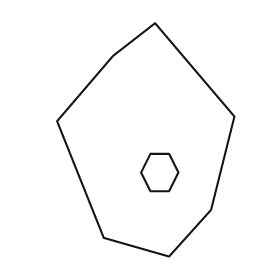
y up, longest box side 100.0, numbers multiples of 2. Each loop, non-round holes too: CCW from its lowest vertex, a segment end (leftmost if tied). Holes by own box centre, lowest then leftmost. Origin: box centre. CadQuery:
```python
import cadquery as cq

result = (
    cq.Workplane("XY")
    .moveTo(10.0, -50.0)
    .lineTo(28.0, -30.0)
    .lineTo(38.0, 10.0)
    .lineTo(4.0, 50.0)
    .lineTo(-14.0, 36.0)
    .lineTo(-38.0, 8.0)
    .lineTo(-18.0, -42.0)
    .close()
    .moveTo(2.0, -22.0)
    .lineTo(10.0, -22.0)
    .lineTo(14.0, -14.0)
    .lineTo(10.0, -6.0)
    .lineTo(2.0, -6.0)
    .lineTo(-2.0, -14.0)
    .close()
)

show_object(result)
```